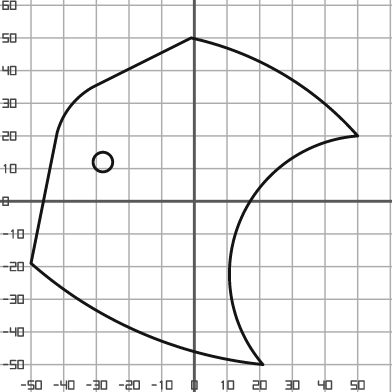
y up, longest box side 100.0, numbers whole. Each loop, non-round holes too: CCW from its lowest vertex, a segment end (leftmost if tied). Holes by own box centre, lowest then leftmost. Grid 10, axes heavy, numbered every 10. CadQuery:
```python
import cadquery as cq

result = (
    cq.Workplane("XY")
    .moveTo(21.0, -50.0)
    .threePointArc((14.0, -6.0), (50.0, 20.0))
    .threePointArc((27.0, 39.0), (-1.0, 50.0))
    .lineTo(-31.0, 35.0)
    .threePointArc((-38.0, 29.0), (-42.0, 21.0))
    .lineTo(-50.0, -19.0)
    .threePointArc((-17.0, -40.0), (21.0, -50.0))
    .close()
    .moveTo(-28.0, 12.0)
    .circle(3.0)
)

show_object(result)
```